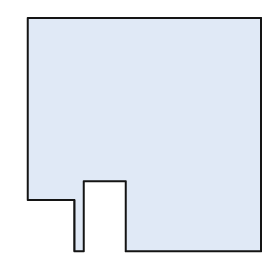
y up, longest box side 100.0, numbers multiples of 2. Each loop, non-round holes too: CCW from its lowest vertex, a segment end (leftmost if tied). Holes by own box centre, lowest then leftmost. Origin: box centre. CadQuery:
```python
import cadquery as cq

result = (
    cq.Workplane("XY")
    .moveTo(-30.0, -50.0)
    .lineTo(-26.0, -50.0)
    .lineTo(-26.0, -20.0)
    .lineTo(-8.0, -20.0)
    .lineTo(-8.0, -50.0)
    .lineTo(50.0, -50.0)
    .lineTo(50.0, 50.0)
    .lineTo(-50.0, 50.0)
    .lineTo(-50.0, -28.0)
    .lineTo(-30.0, -28.0)
    .close()
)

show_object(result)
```